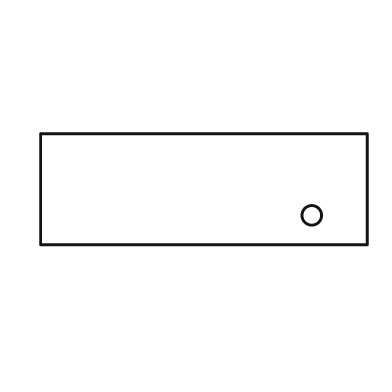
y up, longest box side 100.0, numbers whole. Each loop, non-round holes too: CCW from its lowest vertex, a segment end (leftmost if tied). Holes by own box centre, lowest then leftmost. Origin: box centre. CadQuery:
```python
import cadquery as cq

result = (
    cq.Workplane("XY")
    .moveTo(-50.0, -17.0)
    .lineTo(50.0, -17.0)
    .lineTo(50.0, 17.0)
    .lineTo(-50.0, 17.0)
    .close()
    .moveTo(33.0, -8.0)
    .circle(3.0)
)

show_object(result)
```